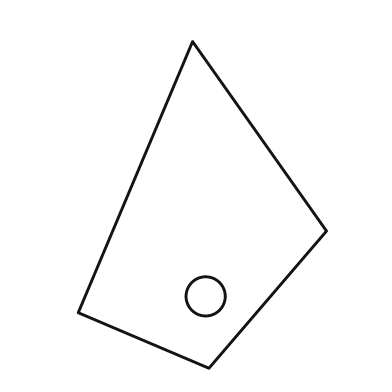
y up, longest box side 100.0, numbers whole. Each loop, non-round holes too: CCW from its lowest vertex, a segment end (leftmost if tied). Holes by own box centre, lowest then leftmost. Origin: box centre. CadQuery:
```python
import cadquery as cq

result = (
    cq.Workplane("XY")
    .moveTo(2.0, -50.0)
    .lineTo(38.0, -8.0)
    .lineTo(-3.0, 50.0)
    .lineTo(-38.0, -33.0)
    .close()
    .moveTo(1.0, -28.0)
    .circle(6.0)
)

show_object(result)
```